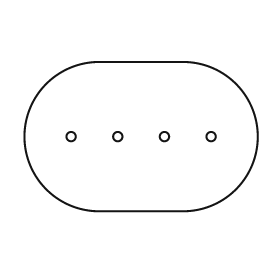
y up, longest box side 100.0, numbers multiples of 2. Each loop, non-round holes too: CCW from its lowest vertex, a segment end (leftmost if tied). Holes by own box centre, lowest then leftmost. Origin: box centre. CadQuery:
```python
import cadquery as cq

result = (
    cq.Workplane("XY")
    .moveTo(-18.0, -32.0)
    .lineTo(18.0, -32.0)
    .threePointArc((50.0, 0.0), (18.0, 32.0))
    .lineTo(-18.0, 32.0)
    .threePointArc((-50.0, 0.0), (-18.0, -32.0))
    .close()
    .moveTo(-30.0, 0.0)
    .circle(2.0)
    .moveTo(-10.0, 0.0)
    .circle(2.0)
    .moveTo(10.0, 0.0)
    .circle(2.0)
    .moveTo(30.0, 0.0)
    .circle(2.0)
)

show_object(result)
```